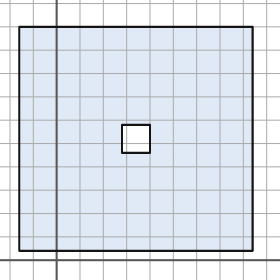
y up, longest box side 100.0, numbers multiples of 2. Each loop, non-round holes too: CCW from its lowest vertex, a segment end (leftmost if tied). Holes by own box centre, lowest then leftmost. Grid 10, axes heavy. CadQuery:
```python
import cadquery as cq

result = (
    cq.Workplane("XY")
    .moveTo(-16.0, 4.0)
    .lineTo(84.0, 4.0)
    .lineTo(84.0, 100.0)
    .lineTo(-16.0, 100.0)
    .close()
    .moveTo(28.0, 46.0)
    .lineTo(40.0, 46.0)
    .lineTo(40.0, 58.0)
    .lineTo(28.0, 58.0)
    .close()
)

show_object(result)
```